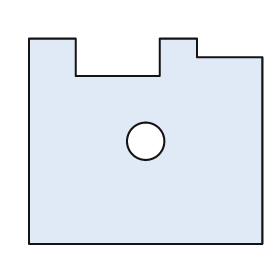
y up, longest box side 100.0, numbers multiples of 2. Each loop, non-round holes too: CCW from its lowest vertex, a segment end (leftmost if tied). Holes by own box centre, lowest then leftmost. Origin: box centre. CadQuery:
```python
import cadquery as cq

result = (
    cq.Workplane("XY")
    .moveTo(-50.0, -44.0)
    .lineTo(50.0, -44.0)
    .lineTo(50.0, 36.0)
    .lineTo(22.0, 36.0)
    .lineTo(22.0, 44.0)
    .lineTo(6.0, 44.0)
    .lineTo(6.0, 28.0)
    .lineTo(-30.0, 28.0)
    .lineTo(-30.0, 44.0)
    .lineTo(-50.0, 44.0)
    .close()
    .moveTo(0.0, 0.0)
    .circle(8.0)
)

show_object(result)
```